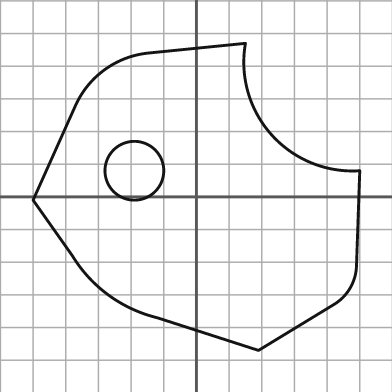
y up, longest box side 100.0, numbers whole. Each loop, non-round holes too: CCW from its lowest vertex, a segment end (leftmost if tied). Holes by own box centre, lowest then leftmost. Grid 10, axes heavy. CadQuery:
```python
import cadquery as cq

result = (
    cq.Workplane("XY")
    .moveTo(19.0, -47.0)
    .lineTo(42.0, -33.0)
    .threePointArc((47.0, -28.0), (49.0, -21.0))
    .lineTo(50.0, 8.0)
    .threePointArc((23.0, 19.0), (15.0, 47.0))
    .lineTo(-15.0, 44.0)
    .threePointArc((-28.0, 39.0), (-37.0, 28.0))
    .lineTo(-50.0, -1.0)
    .lineTo(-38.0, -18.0)
    .threePointArc((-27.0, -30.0), (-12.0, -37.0))
    .close()
    .moveTo(-19.0, 8.0)
    .circle(9.0)
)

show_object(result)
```